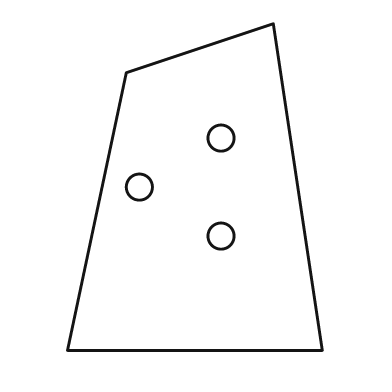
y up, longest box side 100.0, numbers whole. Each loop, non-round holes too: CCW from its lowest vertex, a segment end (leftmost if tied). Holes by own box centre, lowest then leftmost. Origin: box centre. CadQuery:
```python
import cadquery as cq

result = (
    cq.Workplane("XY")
    .moveTo(-39.0, -50.0)
    .lineTo(39.0, -50.0)
    .lineTo(24.0, 50.0)
    .lineTo(-21.0, 35.0)
    .close()
    .moveTo(8.0, -15.0)
    .circle(4.0)
    .moveTo(-17.0, 0.0)
    .circle(4.0)
    .moveTo(8.0, 15.0)
    .circle(4.0)
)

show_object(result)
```